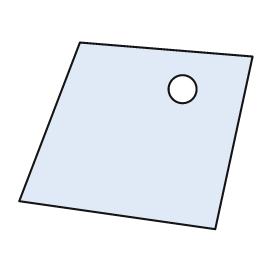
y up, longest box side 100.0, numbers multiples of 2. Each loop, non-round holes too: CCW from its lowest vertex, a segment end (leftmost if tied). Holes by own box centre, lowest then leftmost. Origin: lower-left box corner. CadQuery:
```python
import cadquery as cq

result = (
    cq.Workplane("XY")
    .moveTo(84.0, 0.0)
    .lineTo(100.0, 74.0)
    .lineTo(26.0, 80.0)
    .lineTo(0.0, 12.0)
    .close()
    .moveTo(70.0, 60.0)
    .circle(6.0)
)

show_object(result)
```